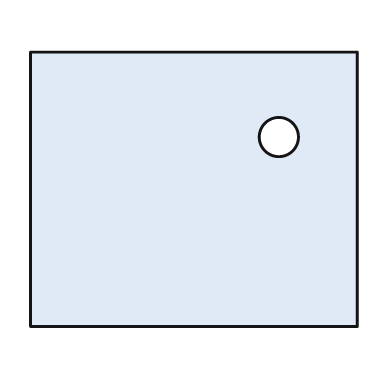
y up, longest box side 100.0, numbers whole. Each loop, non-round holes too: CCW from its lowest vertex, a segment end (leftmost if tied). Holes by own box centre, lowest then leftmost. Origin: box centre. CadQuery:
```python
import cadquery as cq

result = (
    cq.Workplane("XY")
    .moveTo(-50.0, -42.0)
    .lineTo(50.0, -42.0)
    .lineTo(50.0, 42.0)
    .lineTo(-50.0, 42.0)
    .close()
    .moveTo(26.0, 16.0)
    .circle(6.0)
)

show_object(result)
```